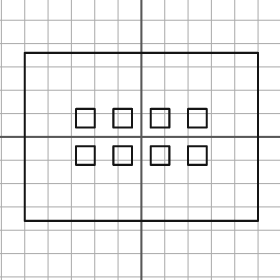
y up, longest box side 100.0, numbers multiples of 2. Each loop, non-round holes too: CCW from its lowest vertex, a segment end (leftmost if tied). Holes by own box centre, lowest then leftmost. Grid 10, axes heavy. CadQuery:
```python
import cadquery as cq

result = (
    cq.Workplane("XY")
    .moveTo(-50.0, -36.0)
    .lineTo(50.0, -36.0)
    .lineTo(50.0, 36.0)
    .lineTo(-50.0, 36.0)
    .close()
    .moveTo(-28.0, -12.0)
    .lineTo(-20.0, -12.0)
    .lineTo(-20.0, -4.0)
    .lineTo(-28.0, -4.0)
    .close()
    .moveTo(-12.0, -12.0)
    .lineTo(-4.0, -12.0)
    .lineTo(-4.0, -4.0)
    .lineTo(-12.0, -4.0)
    .close()
    .moveTo(4.0, -12.0)
    .lineTo(12.0, -12.0)
    .lineTo(12.0, -4.0)
    .lineTo(4.0, -4.0)
    .close()
    .moveTo(20.0, -12.0)
    .lineTo(28.0, -12.0)
    .lineTo(28.0, -4.0)
    .lineTo(20.0, -4.0)
    .close()
    .moveTo(-28.0, 4.0)
    .lineTo(-20.0, 4.0)
    .lineTo(-20.0, 12.0)
    .lineTo(-28.0, 12.0)
    .close()
    .moveTo(-12.0, 4.0)
    .lineTo(-4.0, 4.0)
    .lineTo(-4.0, 12.0)
    .lineTo(-12.0, 12.0)
    .close()
    .moveTo(4.0, 4.0)
    .lineTo(12.0, 4.0)
    .lineTo(12.0, 12.0)
    .lineTo(4.0, 12.0)
    .close()
    .moveTo(20.0, 4.0)
    .lineTo(28.0, 4.0)
    .lineTo(28.0, 12.0)
    .lineTo(20.0, 12.0)
    .close()
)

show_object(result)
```